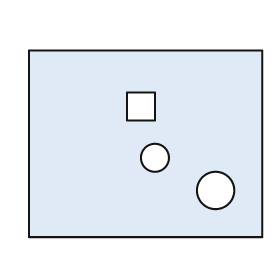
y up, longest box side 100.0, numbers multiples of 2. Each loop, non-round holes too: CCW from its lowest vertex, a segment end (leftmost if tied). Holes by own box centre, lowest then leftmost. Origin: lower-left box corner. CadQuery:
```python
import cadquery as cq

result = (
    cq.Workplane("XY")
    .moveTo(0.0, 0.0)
    .lineTo(100.0, 0.0)
    .lineTo(100.0, 80.0)
    .lineTo(0.0, 80.0)
    .close()
    .moveTo(80.0, 20.0)
    .circle(8.0)
    .moveTo(54.0, 34.0)
    .circle(6.0)
    .moveTo(42.0, 50.0)
    .lineTo(54.0, 50.0)
    .lineTo(54.0, 62.0)
    .lineTo(42.0, 62.0)
    .close()
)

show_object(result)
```